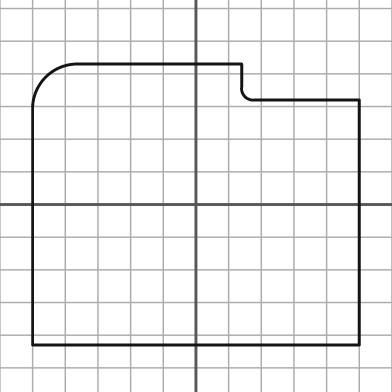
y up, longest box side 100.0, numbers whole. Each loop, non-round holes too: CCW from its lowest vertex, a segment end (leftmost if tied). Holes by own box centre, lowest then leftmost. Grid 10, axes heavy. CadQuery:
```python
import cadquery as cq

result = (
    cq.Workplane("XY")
    .moveTo(-50.0, -43.0)
    .lineTo(50.0, -43.0)
    .lineTo(50.0, 32.0)
    .lineTo(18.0, 32.0)
    .threePointArc((15.0, 33.0), (14.0, 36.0))
    .lineTo(14.0, 43.0)
    .lineTo(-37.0, 43.0)
    .threePointArc((-46.0, 39.0), (-50.0, 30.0))
    .close()
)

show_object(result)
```